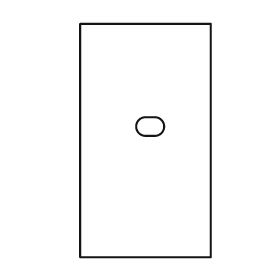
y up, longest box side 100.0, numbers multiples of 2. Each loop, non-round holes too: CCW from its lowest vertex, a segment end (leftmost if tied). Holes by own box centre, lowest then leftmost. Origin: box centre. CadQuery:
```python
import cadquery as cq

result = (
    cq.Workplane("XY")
    .moveTo(-28.0, -50.0)
    .lineTo(28.0, -50.0)
    .lineTo(28.0, 50.0)
    .lineTo(-28.0, 50.0)
    .close()
    .moveTo(0.0, 2.0)
    .lineTo(4.0, 2.0)
    .threePointArc((8.0, 6.0), (4.0, 10.0))
    .lineTo(0.0, 10.0)
    .threePointArc((-4.0, 6.0), (0.0, 2.0))
    .close()
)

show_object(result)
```